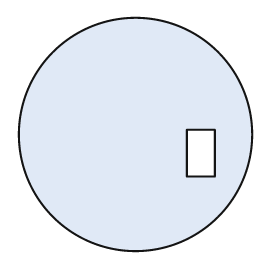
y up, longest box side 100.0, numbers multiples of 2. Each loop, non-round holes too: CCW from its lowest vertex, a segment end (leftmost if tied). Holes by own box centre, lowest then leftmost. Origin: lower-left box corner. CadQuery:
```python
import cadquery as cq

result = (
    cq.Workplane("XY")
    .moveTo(50.0, 50.0)
    .circle(50.0)
    .moveTo(72.0, 32.0)
    .lineTo(84.0, 32.0)
    .lineTo(84.0, 52.0)
    .lineTo(72.0, 52.0)
    .close()
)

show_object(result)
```